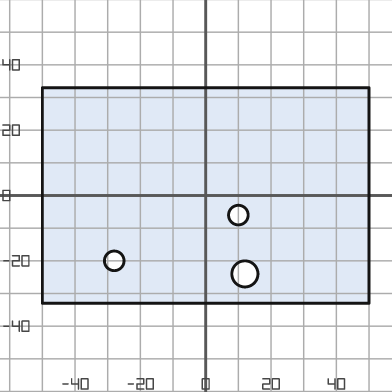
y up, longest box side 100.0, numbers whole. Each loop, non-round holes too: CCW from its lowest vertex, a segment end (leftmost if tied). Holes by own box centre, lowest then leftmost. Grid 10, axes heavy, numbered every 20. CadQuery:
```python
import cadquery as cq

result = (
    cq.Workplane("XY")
    .moveTo(-50.0, -33.0)
    .lineTo(50.0, -33.0)
    .lineTo(50.0, 33.0)
    .lineTo(-50.0, 33.0)
    .close()
    .moveTo(12.0, -24.0)
    .circle(4.0)
    .moveTo(-28.0, -20.0)
    .circle(3.0)
    .moveTo(10.0, -6.0)
    .circle(3.0)
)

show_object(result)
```